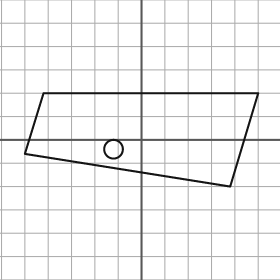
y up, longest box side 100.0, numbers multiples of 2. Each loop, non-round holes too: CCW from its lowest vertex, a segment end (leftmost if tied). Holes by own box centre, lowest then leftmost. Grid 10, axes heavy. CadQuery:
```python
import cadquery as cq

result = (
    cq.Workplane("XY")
    .moveTo(38.0, -20.0)
    .lineTo(50.0, 20.0)
    .lineTo(-42.0, 20.0)
    .lineTo(-50.0, -6.0)
    .close()
    .moveTo(-12.0, -4.0)
    .circle(4.0)
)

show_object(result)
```